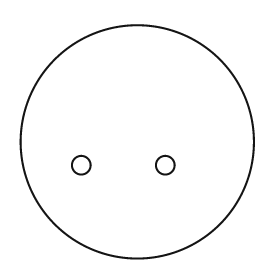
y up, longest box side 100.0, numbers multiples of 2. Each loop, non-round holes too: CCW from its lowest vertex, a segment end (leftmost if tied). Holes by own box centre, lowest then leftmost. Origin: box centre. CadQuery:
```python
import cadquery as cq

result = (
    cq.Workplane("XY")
    .moveTo(0.0, 0.0)
    .circle(50.0)
    .moveTo(-24.0, -10.0)
    .circle(4.0)
    .moveTo(12.0, -10.0)
    .circle(4.0)
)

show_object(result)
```